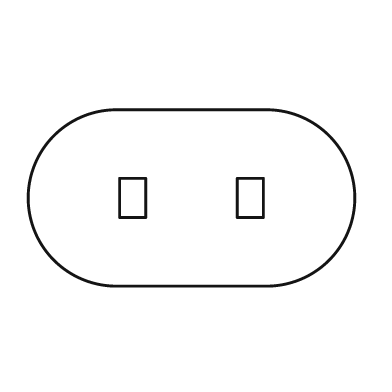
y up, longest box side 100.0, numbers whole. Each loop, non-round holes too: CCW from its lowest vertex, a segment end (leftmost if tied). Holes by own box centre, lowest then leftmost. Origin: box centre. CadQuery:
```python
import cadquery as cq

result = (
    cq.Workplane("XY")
    .moveTo(-23.0, -27.0)
    .lineTo(23.0, -27.0)
    .threePointArc((50.0, 0.0), (23.0, 27.0))
    .lineTo(-23.0, 27.0)
    .threePointArc((-50.0, 0.0), (-23.0, -27.0))
    .close()
    .moveTo(-22.0, -6.0)
    .lineTo(-14.0, -6.0)
    .lineTo(-14.0, 6.0)
    .lineTo(-22.0, 6.0)
    .close()
    .moveTo(14.0, -6.0)
    .lineTo(22.0, -6.0)
    .lineTo(22.0, 6.0)
    .lineTo(14.0, 6.0)
    .close()
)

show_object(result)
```